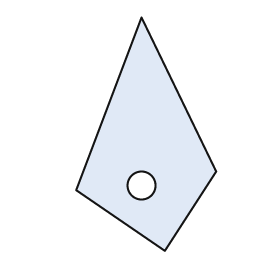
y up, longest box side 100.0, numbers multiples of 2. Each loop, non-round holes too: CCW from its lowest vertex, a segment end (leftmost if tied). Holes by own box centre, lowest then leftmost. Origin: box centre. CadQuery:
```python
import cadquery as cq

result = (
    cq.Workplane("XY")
    .moveTo(8.0, -50.0)
    .lineTo(30.0, -16.0)
    .lineTo(-2.0, 50.0)
    .lineTo(-30.0, -24.0)
    .close()
    .moveTo(-2.0, -22.0)
    .circle(6.0)
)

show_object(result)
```